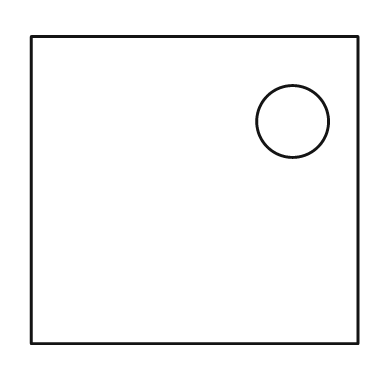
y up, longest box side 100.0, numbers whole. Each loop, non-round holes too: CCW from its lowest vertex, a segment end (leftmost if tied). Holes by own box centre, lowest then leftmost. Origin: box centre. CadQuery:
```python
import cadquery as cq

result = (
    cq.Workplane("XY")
    .moveTo(-50.0, -47.0)
    .lineTo(50.0, -47.0)
    .lineTo(50.0, 47.0)
    .lineTo(-50.0, 47.0)
    .close()
    .moveTo(30.0, 21.0)
    .circle(11.0)
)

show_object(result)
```